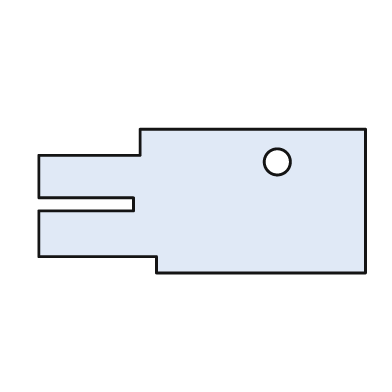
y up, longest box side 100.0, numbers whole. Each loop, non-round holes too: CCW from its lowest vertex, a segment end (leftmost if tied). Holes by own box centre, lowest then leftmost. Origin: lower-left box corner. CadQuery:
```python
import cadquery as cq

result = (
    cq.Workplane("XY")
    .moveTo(36.0, 0.0)
    .lineTo(100.0, 0.0)
    .lineTo(100.0, 44.0)
    .lineTo(31.0, 44.0)
    .lineTo(31.0, 36.0)
    .lineTo(0.0, 36.0)
    .lineTo(0.0, 23.0)
    .lineTo(29.0, 23.0)
    .lineTo(29.0, 19.0)
    .lineTo(0.0, 19.0)
    .lineTo(0.0, 5.0)
    .lineTo(36.0, 5.0)
    .close()
    .moveTo(73.0, 34.0)
    .circle(4.0)
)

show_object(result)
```